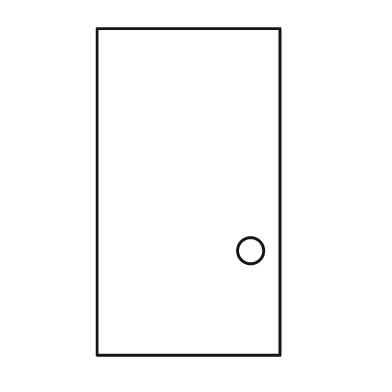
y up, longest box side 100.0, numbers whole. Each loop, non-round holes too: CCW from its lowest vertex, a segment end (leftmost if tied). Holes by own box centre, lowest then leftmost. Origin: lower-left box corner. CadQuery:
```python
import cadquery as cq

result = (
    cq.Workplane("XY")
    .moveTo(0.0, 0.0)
    .lineTo(56.0, 0.0)
    .lineTo(56.0, 100.0)
    .lineTo(0.0, 100.0)
    .close()
    .moveTo(47.0, 32.0)
    .circle(4.0)
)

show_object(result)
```